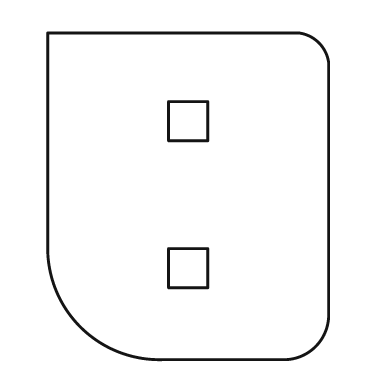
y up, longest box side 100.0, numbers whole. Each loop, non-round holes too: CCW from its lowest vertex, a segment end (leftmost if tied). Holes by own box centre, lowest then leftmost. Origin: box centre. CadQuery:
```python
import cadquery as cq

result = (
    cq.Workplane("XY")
    .moveTo(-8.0, -50.0)
    .lineTo(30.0, -50.0)
    .threePointArc((39.0, -46.0), (43.0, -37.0))
    .lineTo(43.0, 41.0)
    .threePointArc((40.0, 47.0), (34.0, 50.0))
    .lineTo(-43.0, 50.0)
    .lineTo(-43.0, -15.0)
    .threePointArc((-33.0, -40.0), (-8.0, -50.0))
    .close()
    .moveTo(-6.0, -28.0)
    .lineTo(6.0, -28.0)
    .lineTo(6.0, -16.0)
    .lineTo(-6.0, -16.0)
    .close()
    .moveTo(-6.0, 17.0)
    .lineTo(6.0, 17.0)
    .lineTo(6.0, 29.0)
    .lineTo(-6.0, 29.0)
    .close()
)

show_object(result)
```